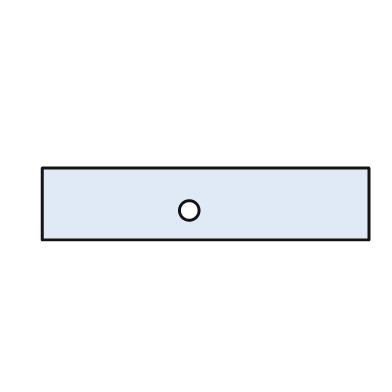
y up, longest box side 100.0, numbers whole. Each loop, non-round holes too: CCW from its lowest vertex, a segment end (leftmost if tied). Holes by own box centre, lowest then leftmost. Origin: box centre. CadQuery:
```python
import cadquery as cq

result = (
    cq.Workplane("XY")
    .moveTo(-50.0, -11.0)
    .lineTo(50.0, -11.0)
    .lineTo(50.0, 11.0)
    .lineTo(-50.0, 11.0)
    .close()
    .moveTo(-5.0, -2.0)
    .circle(3.0)
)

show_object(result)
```